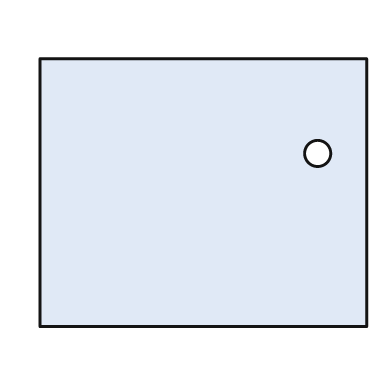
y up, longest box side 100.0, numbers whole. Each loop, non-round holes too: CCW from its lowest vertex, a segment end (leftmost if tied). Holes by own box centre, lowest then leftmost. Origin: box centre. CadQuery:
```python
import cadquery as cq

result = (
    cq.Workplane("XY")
    .moveTo(-50.0, -41.0)
    .lineTo(50.0, -41.0)
    .lineTo(50.0, 41.0)
    .lineTo(-50.0, 41.0)
    .close()
    .moveTo(35.0, 12.0)
    .circle(4.0)
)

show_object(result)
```